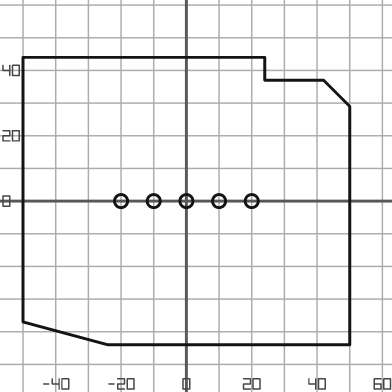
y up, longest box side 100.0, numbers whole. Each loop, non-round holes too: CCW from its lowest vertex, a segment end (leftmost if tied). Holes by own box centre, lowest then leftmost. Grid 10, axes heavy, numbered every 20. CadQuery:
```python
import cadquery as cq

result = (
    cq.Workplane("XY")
    .moveTo(-24.0, -44.0)
    .lineTo(50.0, -44.0)
    .lineTo(50.0, 29.0)
    .lineTo(42.0, 37.0)
    .lineTo(24.0, 37.0)
    .lineTo(24.0, 44.0)
    .lineTo(-50.0, 44.0)
    .lineTo(-50.0, -37.0)
    .close()
    .moveTo(-20.0, 0.0)
    .circle(2.0)
    .moveTo(-10.0, 0.0)
    .circle(2.0)
    .moveTo(0.0, 0.0)
    .circle(2.0)
    .moveTo(10.0, 0.0)
    .circle(2.0)
    .moveTo(20.0, 0.0)
    .circle(2.0)
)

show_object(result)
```